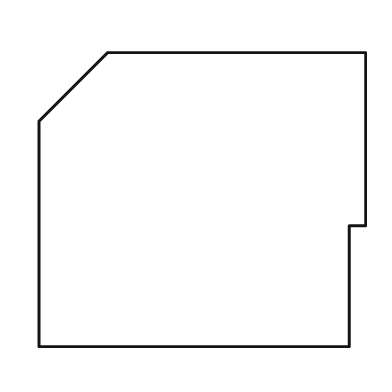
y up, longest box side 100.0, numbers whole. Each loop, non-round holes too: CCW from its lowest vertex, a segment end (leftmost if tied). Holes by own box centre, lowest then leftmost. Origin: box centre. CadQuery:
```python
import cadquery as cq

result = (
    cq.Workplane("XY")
    .moveTo(-50.0, -45.0)
    .lineTo(45.0, -45.0)
    .lineTo(45.0, -8.0)
    .lineTo(50.0, -8.0)
    .lineTo(50.0, 45.0)
    .lineTo(-29.0, 45.0)
    .lineTo(-50.0, 24.0)
    .close()
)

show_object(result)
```